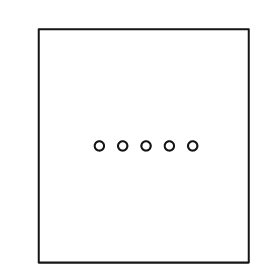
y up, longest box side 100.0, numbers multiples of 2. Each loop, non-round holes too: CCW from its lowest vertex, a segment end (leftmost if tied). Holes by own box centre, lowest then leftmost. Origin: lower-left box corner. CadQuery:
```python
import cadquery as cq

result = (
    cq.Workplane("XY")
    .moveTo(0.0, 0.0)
    .lineTo(90.0, 0.0)
    .lineTo(90.0, 100.0)
    .lineTo(0.0, 100.0)
    .close()
    .moveTo(26.0, 50.0)
    .circle(2.0)
    .moveTo(36.0, 50.0)
    .circle(2.0)
    .moveTo(46.0, 50.0)
    .circle(2.0)
    .moveTo(56.0, 50.0)
    .circle(2.0)
    .moveTo(66.0, 50.0)
    .circle(2.0)
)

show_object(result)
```